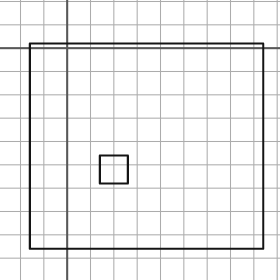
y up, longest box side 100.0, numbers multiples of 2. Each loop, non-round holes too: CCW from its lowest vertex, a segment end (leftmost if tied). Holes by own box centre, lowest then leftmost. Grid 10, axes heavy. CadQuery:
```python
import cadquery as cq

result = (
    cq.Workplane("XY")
    .moveTo(-16.0, -86.0)
    .lineTo(84.0, -86.0)
    .lineTo(84.0, 2.0)
    .lineTo(-16.0, 2.0)
    .close()
    .moveTo(14.0, -58.0)
    .lineTo(26.0, -58.0)
    .lineTo(26.0, -46.0)
    .lineTo(14.0, -46.0)
    .close()
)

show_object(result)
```